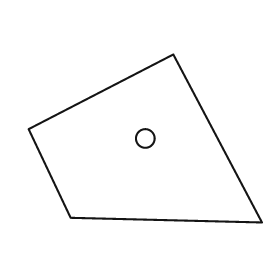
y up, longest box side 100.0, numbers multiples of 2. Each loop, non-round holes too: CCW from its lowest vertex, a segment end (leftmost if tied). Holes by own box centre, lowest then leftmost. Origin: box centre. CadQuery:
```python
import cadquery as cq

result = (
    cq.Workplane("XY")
    .moveTo(50.0, -36.0)
    .lineTo(12.0, 36.0)
    .lineTo(-50.0, 4.0)
    .lineTo(-32.0, -34.0)
    .close()
    .moveTo(0.0, 0.0)
    .circle(4.0)
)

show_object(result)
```